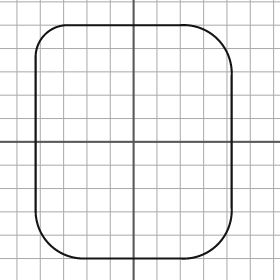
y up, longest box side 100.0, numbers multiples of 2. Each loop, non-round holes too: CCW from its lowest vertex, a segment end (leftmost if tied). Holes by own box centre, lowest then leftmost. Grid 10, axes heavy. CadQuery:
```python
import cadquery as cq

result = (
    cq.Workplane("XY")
    .moveTo(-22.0, -50.0)
    .lineTo(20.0, -50.0)
    .threePointArc((36.0, -44.0), (42.0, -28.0))
    .lineTo(42.0, 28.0)
    .threePointArc((36.0, 44.0), (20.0, 50.0))
    .lineTo(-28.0, 50.0)
    .threePointArc((-38.0, 46.0), (-42.0, 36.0))
    .lineTo(-42.0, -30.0)
    .threePointArc((-36.0, -44.0), (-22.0, -50.0))
    .close()
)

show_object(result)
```